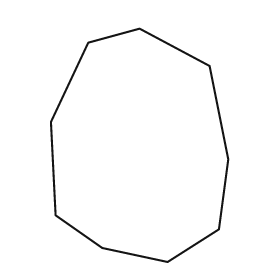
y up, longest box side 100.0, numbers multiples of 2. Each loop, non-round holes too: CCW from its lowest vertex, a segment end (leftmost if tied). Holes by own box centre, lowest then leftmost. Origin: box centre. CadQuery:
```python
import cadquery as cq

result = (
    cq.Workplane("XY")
    .moveTo(12.0, -50.0)
    .lineTo(34.0, -36.0)
    .lineTo(38.0, -6.0)
    .lineTo(30.0, 34.0)
    .lineTo(0.0, 50.0)
    .lineTo(-22.0, 44.0)
    .lineTo(-38.0, 10.0)
    .lineTo(-36.0, -30.0)
    .lineTo(-16.0, -44.0)
    .close()
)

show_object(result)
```